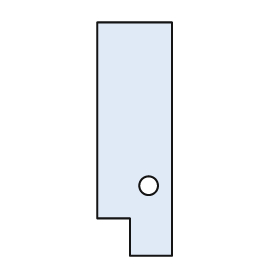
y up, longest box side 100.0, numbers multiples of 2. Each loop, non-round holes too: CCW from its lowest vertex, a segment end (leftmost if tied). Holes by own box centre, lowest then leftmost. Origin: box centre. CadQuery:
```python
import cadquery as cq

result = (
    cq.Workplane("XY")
    .moveTo(-2.0, -50.0)
    .lineTo(16.0, -50.0)
    .lineTo(16.0, 50.0)
    .lineTo(-16.0, 50.0)
    .lineTo(-16.0, -34.0)
    .lineTo(-2.0, -34.0)
    .close()
    .moveTo(6.0, -20.0)
    .circle(4.0)
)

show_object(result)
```